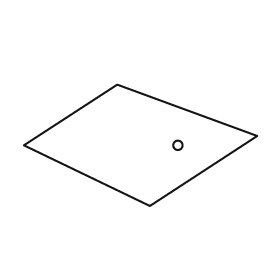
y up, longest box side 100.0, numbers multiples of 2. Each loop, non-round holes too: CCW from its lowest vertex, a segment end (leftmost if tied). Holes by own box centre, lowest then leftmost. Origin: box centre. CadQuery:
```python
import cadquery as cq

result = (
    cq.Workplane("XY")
    .moveTo(4.0, -26.0)
    .lineTo(50.0, 4.0)
    .lineTo(-10.0, 26.0)
    .lineTo(-50.0, 0.0)
    .close()
    .moveTo(16.0, 0.0)
    .circle(2.0)
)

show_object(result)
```